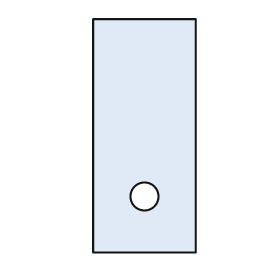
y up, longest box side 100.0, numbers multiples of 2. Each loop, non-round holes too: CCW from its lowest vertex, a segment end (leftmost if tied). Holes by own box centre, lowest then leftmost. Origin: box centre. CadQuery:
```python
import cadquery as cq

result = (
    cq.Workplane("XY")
    .moveTo(-22.0, -50.0)
    .lineTo(22.0, -50.0)
    .lineTo(22.0, 50.0)
    .lineTo(-22.0, 50.0)
    .close()
    .moveTo(0.0, -26.0)
    .circle(6.0)
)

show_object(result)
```